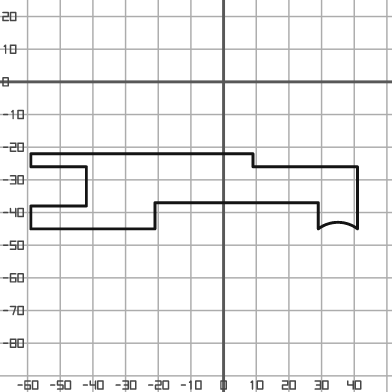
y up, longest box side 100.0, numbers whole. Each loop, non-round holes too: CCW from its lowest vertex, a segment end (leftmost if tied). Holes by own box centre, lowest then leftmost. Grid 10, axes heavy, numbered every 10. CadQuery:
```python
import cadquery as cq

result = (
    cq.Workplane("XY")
    .moveTo(-59.0, -45.0)
    .lineTo(-21.0, -45.0)
    .lineTo(-21.0, -37.0)
    .lineTo(29.0, -37.0)
    .lineTo(29.0, -45.0)
    .threePointArc((35.0, -43.0), (41.0, -45.0))
    .lineTo(41.0, -26.0)
    .lineTo(9.0, -26.0)
    .lineTo(9.0, -22.0)
    .lineTo(-59.0, -22.0)
    .lineTo(-59.0, -26.0)
    .lineTo(-42.0, -26.0)
    .lineTo(-42.0, -38.0)
    .lineTo(-59.0, -38.0)
    .close()
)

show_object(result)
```